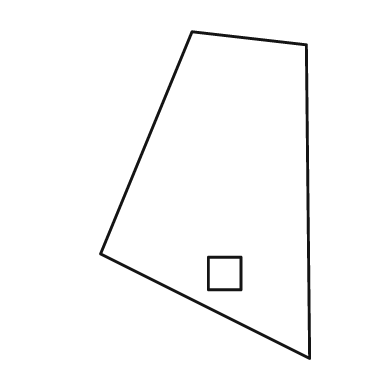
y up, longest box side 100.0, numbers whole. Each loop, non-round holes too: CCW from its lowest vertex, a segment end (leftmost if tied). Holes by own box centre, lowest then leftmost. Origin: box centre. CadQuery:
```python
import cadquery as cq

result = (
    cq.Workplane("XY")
    .moveTo(32.0, -50.0)
    .lineTo(31.0, 46.0)
    .lineTo(-4.0, 50.0)
    .lineTo(-32.0, -18.0)
    .close()
    .moveTo(1.0, -29.0)
    .lineTo(11.0, -29.0)
    .lineTo(11.0, -19.0)
    .lineTo(1.0, -19.0)
    .close()
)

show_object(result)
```